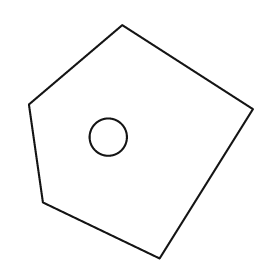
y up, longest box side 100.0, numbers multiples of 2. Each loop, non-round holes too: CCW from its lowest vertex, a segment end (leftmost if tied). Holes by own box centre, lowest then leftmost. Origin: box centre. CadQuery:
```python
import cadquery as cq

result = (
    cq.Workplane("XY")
    .moveTo(8.0, -50.0)
    .lineTo(48.0, 14.0)
    .lineTo(-8.0, 50.0)
    .lineTo(-48.0, 16.0)
    .lineTo(-42.0, -26.0)
    .close()
    .moveTo(-14.0, 2.0)
    .circle(8.0)
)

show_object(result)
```